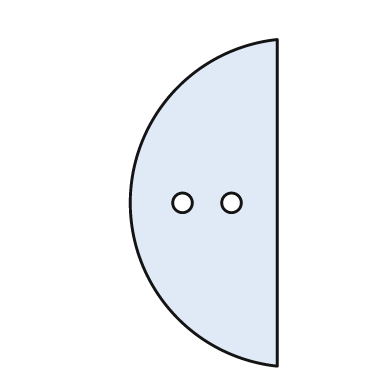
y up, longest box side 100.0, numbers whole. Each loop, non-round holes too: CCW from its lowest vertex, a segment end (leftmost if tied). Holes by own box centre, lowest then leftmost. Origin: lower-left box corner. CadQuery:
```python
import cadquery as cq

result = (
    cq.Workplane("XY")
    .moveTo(45.0, 0.0)
    .lineTo(45.0, 100.0)
    .threePointArc((0.0, 50.0), (45.0, 0.0))
    .close()
    .moveTo(16.0, 50.0)
    .circle(3.0)
    .moveTo(31.0, 50.0)
    .circle(3.0)
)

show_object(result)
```